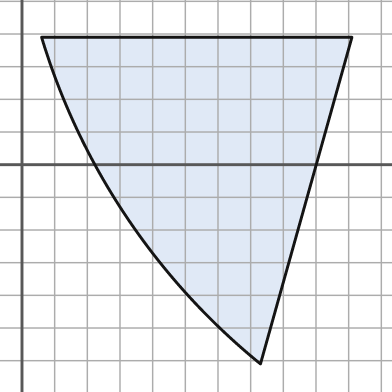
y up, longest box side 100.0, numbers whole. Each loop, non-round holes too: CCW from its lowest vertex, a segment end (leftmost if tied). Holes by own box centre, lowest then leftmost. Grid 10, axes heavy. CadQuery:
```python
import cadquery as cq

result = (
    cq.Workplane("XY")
    .moveTo(73.0, -61.0)
    .lineTo(101.0, 39.0)
    .lineTo(6.0, 39.0)
    .threePointArc((32.0, -16.0), (73.0, -61.0))
    .close()
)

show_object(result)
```